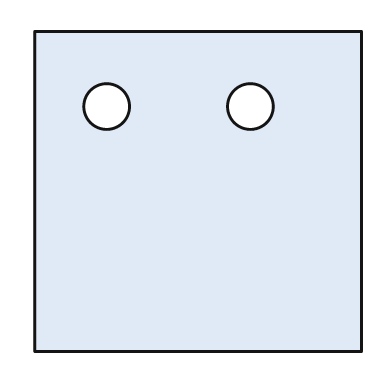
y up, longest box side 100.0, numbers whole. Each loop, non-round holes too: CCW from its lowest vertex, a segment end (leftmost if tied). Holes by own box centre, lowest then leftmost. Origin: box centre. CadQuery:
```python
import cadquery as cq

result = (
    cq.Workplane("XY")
    .moveTo(-50.0, -49.0)
    .lineTo(50.0, -49.0)
    .lineTo(50.0, 49.0)
    .lineTo(-50.0, 49.0)
    .close()
    .moveTo(-28.0, 26.0)
    .circle(7.0)
    .moveTo(16.0, 26.0)
    .circle(7.0)
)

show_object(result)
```